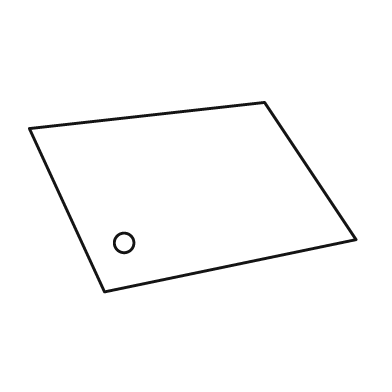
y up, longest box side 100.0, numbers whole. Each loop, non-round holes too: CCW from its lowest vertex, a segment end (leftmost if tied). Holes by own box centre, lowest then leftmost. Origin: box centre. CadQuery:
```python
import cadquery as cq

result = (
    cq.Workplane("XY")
    .moveTo(-27.0, -29.0)
    .lineTo(50.0, -13.0)
    .lineTo(22.0, 29.0)
    .lineTo(-50.0, 21.0)
    .close()
    .moveTo(-21.0, -14.0)
    .circle(3.0)
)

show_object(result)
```